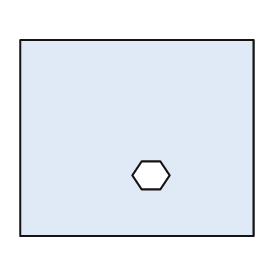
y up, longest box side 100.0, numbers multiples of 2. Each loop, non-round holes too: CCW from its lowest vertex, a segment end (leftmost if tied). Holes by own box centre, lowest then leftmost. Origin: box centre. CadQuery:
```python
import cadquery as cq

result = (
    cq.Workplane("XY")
    .moveTo(-50.0, -42.0)
    .lineTo(50.0, -42.0)
    .lineTo(50.0, 42.0)
    .lineTo(-50.0, 42.0)
    .close()
    .moveTo(2.0, -22.0)
    .lineTo(10.0, -22.0)
    .lineTo(14.0, -16.0)
    .lineTo(10.0, -10.0)
    .lineTo(2.0, -10.0)
    .lineTo(-2.0, -16.0)
    .close()
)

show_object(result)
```